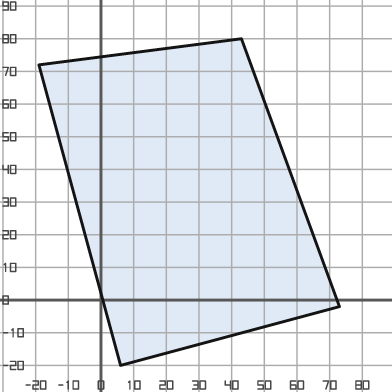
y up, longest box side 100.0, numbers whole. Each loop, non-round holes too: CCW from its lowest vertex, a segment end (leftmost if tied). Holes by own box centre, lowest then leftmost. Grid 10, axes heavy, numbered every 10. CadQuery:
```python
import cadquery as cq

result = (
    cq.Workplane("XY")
    .moveTo(6.0, -20.0)
    .lineTo(73.0, -2.0)
    .lineTo(43.0, 80.0)
    .lineTo(-19.0, 72.0)
    .close()
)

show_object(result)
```